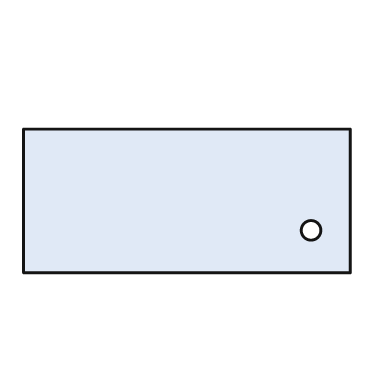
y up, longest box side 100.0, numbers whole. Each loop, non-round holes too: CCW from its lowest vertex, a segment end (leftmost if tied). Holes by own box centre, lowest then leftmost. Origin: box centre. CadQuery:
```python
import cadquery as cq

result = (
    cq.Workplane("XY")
    .moveTo(-50.0, -22.0)
    .lineTo(50.0, -22.0)
    .lineTo(50.0, 22.0)
    .lineTo(-50.0, 22.0)
    .close()
    .moveTo(38.0, -9.0)
    .circle(3.0)
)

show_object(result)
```